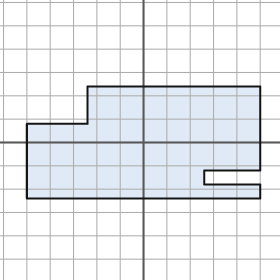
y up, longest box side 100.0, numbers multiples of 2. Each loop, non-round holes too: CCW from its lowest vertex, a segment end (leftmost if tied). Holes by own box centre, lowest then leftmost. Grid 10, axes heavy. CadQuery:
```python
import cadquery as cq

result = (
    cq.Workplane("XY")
    .moveTo(-50.0, -24.0)
    .lineTo(50.0, -24.0)
    .lineTo(50.0, -18.0)
    .lineTo(26.0, -18.0)
    .lineTo(26.0, -12.0)
    .lineTo(50.0, -12.0)
    .lineTo(50.0, 24.0)
    .lineTo(-24.0, 24.0)
    .lineTo(-24.0, 8.0)
    .lineTo(-50.0, 8.0)
    .close()
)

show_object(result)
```